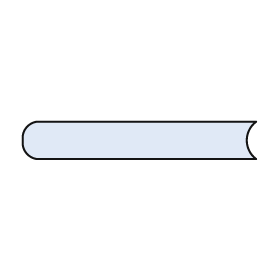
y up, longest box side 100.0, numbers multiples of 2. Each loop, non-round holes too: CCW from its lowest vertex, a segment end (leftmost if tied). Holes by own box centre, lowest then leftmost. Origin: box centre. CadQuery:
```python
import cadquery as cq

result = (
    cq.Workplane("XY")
    .moveTo(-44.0, -8.0)
    .lineTo(50.0, -8.0)
    .threePointArc((46.0, 0.0), (50.0, 8.0))
    .lineTo(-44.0, 8.0)
    .threePointArc((-48.0, 6.0), (-50.0, 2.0))
    .lineTo(-50.0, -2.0)
    .threePointArc((-48.0, -6.0), (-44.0, -8.0))
    .close()
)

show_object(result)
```